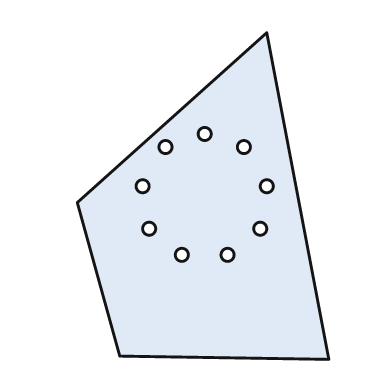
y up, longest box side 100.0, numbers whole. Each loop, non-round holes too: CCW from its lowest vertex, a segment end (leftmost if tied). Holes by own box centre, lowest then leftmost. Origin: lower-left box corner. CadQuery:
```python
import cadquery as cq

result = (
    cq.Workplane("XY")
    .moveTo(77.0, 0.0)
    .lineTo(58.0, 100.0)
    .lineTo(0.0, 48.0)
    .lineTo(13.0, 1.0)
    .close()
    .moveTo(32.0, 32.0)
    .circle(2.0)
    .moveTo(46.0, 32.0)
    .circle(2.0)
    .moveTo(22.0, 40.0)
    .circle(2.0)
    .moveTo(56.0, 40.0)
    .circle(2.0)
    .moveTo(20.0, 53.0)
    .circle(2.0)
    .moveTo(58.0, 53.0)
    .circle(2.0)
    .moveTo(27.0, 65.0)
    .circle(2.0)
    .moveTo(51.0, 65.0)
    .circle(2.0)
    .moveTo(39.0, 69.0)
    .circle(2.0)
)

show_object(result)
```